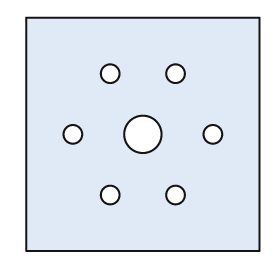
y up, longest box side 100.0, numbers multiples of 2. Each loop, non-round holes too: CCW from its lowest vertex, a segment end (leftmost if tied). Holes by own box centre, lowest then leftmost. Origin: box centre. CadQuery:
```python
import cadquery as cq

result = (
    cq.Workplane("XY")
    .moveTo(-50.0, -50.0)
    .lineTo(50.0, -50.0)
    .lineTo(50.0, 50.0)
    .lineTo(-50.0, 50.0)
    .close()
    .moveTo(-14.0, -26.0)
    .circle(4.0)
    .moveTo(14.0, -26.0)
    .circle(4.0)
    .moveTo(-30.0, 0.0)
    .circle(4.0)
    .moveTo(0.0, 0.0)
    .circle(8.0)
    .moveTo(30.0, 0.0)
    .circle(4.0)
    .moveTo(-14.0, 26.0)
    .circle(4.0)
    .moveTo(14.0, 26.0)
    .circle(4.0)
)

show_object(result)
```